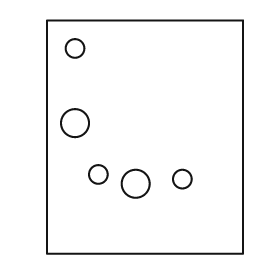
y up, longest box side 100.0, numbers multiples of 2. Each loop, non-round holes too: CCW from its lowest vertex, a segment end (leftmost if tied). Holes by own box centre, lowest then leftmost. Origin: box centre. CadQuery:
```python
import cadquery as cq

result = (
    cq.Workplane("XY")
    .moveTo(-42.0, -50.0)
    .lineTo(42.0, -50.0)
    .lineTo(42.0, 50.0)
    .lineTo(-42.0, 50.0)
    .close()
    .moveTo(-4.0, -20.0)
    .circle(6.0)
    .moveTo(16.0, -18.0)
    .circle(4.0)
    .moveTo(-20.0, -16.0)
    .circle(4.0)
    .moveTo(-30.0, 6.0)
    .circle(6.0)
    .moveTo(-30.0, 38.0)
    .circle(4.0)
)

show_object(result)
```